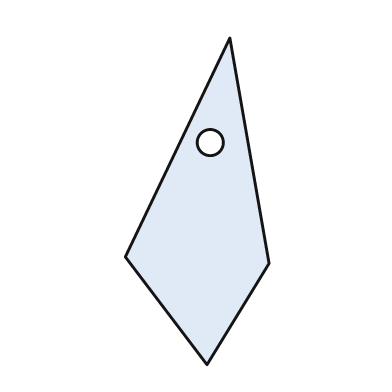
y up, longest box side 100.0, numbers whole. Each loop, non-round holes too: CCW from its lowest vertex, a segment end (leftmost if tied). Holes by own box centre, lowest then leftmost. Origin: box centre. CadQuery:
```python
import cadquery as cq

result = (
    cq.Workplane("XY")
    .moveTo(3.0, -50.0)
    .lineTo(22.0, -19.0)
    .lineTo(10.0, 50.0)
    .lineTo(-22.0, -17.0)
    .close()
    .moveTo(4.0, 18.0)
    .circle(4.0)
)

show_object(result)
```